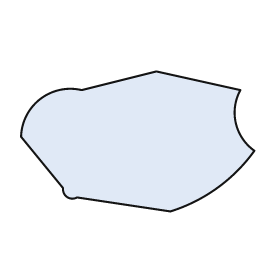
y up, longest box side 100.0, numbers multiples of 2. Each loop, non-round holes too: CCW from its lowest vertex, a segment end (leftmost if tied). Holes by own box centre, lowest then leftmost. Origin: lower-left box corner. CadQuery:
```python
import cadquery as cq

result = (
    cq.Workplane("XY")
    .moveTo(64.0, 0.0)
    .threePointArc((84.0, 10.0), (100.0, 26.0))
    .threePointArc((92.0, 38.0), (94.0, 52.0))
    .lineTo(58.0, 60.0)
    .lineTo(26.0, 52.0)
    .threePointArc((8.0, 48.0), (0.0, 32.0))
    .lineTo(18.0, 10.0)
    .threePointArc((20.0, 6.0), (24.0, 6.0))
    .close()
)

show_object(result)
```